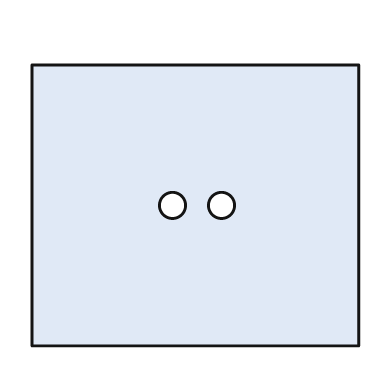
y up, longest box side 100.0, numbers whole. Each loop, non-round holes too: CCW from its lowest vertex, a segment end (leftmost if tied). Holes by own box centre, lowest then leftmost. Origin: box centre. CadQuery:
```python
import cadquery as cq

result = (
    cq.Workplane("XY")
    .moveTo(-50.0, -43.0)
    .lineTo(50.0, -43.0)
    .lineTo(50.0, 43.0)
    .lineTo(-50.0, 43.0)
    .close()
    .moveTo(-7.0, 0.0)
    .circle(4.0)
    .moveTo(8.0, 0.0)
    .circle(4.0)
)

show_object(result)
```